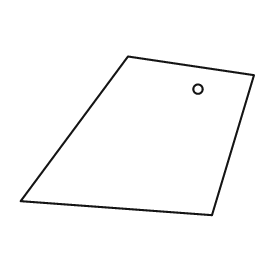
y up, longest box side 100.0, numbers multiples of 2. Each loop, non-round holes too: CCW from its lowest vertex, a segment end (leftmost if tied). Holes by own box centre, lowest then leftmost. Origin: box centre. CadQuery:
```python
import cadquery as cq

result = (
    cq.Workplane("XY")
    .moveTo(32.0, -34.0)
    .lineTo(50.0, 26.0)
    .lineTo(-4.0, 34.0)
    .lineTo(-50.0, -28.0)
    .close()
    .moveTo(26.0, 20.0)
    .circle(2.0)
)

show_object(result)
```